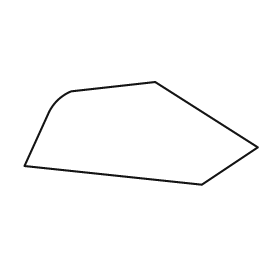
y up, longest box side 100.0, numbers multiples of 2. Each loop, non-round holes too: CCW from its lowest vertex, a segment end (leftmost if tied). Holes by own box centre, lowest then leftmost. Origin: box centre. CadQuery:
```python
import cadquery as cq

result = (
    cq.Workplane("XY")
    .moveTo(26.0, -22.0)
    .lineTo(50.0, -6.0)
    .lineTo(6.0, 22.0)
    .lineTo(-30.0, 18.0)
    .threePointArc((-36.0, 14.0), (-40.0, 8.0))
    .lineTo(-50.0, -14.0)
    .close()
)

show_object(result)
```